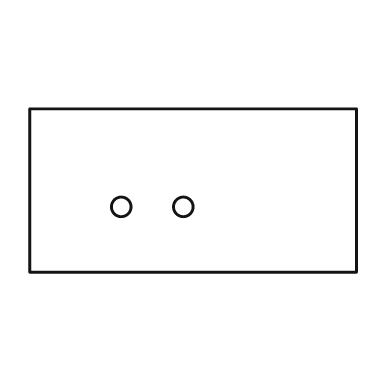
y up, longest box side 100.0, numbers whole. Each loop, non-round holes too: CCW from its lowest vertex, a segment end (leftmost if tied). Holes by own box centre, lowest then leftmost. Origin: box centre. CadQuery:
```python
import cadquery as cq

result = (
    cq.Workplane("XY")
    .moveTo(-50.0, -25.0)
    .lineTo(50.0, -25.0)
    .lineTo(50.0, 25.0)
    .lineTo(-50.0, 25.0)
    .close()
    .moveTo(-22.0, -5.0)
    .circle(3.0)
    .moveTo(-3.0, -5.0)
    .circle(3.0)
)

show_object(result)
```